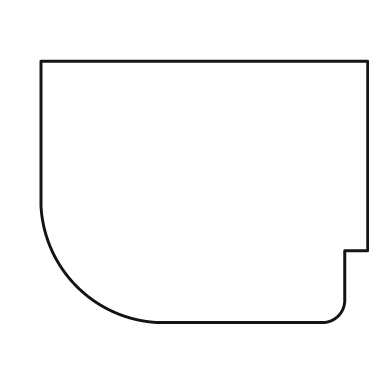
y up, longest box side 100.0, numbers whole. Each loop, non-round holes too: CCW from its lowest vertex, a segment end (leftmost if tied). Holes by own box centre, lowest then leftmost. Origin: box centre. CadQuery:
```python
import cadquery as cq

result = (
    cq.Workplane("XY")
    .moveTo(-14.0, -40.0)
    .lineTo(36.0, -40.0)
    .threePointArc((41.0, -38.0), (43.0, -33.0))
    .lineTo(43.0, -18.0)
    .lineTo(50.0, -18.0)
    .lineTo(50.0, 40.0)
    .lineTo(-50.0, 40.0)
    .lineTo(-50.0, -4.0)
    .threePointArc((-39.0, -29.0), (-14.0, -40.0))
    .close()
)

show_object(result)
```